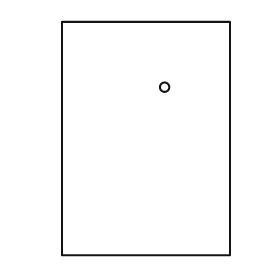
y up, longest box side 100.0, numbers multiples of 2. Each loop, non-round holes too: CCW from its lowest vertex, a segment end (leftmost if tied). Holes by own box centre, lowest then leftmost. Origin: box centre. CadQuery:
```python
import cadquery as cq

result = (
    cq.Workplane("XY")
    .moveTo(-36.0, -50.0)
    .lineTo(36.0, -50.0)
    .lineTo(36.0, 50.0)
    .lineTo(-36.0, 50.0)
    .close()
    .moveTo(8.0, 22.0)
    .circle(2.0)
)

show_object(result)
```